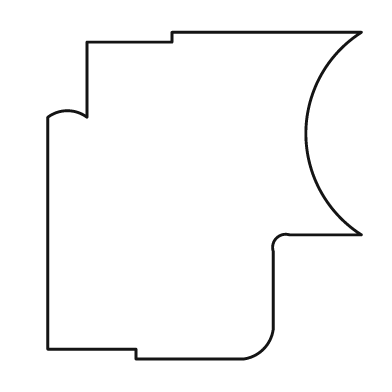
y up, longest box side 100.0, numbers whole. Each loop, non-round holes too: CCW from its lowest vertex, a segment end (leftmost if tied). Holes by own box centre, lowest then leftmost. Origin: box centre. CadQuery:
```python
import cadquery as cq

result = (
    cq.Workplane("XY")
    .moveTo(-21.0, -50.0)
    .lineTo(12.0, -50.0)
    .threePointArc((18.0, -47.0), (21.0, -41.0))
    .lineTo(21.0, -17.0)
    .threePointArc((22.0, -13.0), (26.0, -12.0))
    .lineTo(48.0, -12.0)
    .threePointArc((31.0, 19.0), (48.0, 50.0))
    .lineTo(-10.0, 50.0)
    .lineTo(-10.0, 47.0)
    .lineTo(-36.0, 47.0)
    .lineTo(-36.0, 24.0)
    .threePointArc((-42.0, 26.0), (-48.0, 24.0))
    .lineTo(-48.0, -47.0)
    .lineTo(-21.0, -47.0)
    .close()
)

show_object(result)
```